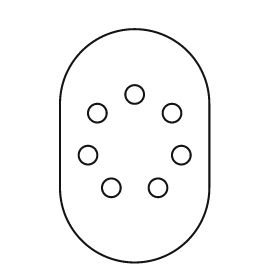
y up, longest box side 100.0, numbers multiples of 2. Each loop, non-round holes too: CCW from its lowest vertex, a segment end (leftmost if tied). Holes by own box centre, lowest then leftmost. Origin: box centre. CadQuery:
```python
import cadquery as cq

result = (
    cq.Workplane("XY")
    .moveTo(-32.0, -18.0)
    .threePointArc((0.0, -50.0), (32.0, -18.0))
    .lineTo(32.0, 18.0)
    .threePointArc((0.0, 50.0), (-32.0, 18.0))
    .close()
    .moveTo(-10.0, -18.0)
    .circle(4.0)
    .moveTo(10.0, -18.0)
    .circle(4.0)
    .moveTo(-20.0, -4.0)
    .circle(4.0)
    .moveTo(20.0, -4.0)
    .circle(4.0)
    .moveTo(-16.0, 14.0)
    .circle(4.0)
    .moveTo(16.0, 14.0)
    .circle(4.0)
    .moveTo(0.0, 22.0)
    .circle(4.0)
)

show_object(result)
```